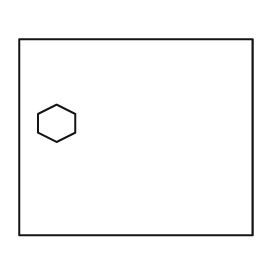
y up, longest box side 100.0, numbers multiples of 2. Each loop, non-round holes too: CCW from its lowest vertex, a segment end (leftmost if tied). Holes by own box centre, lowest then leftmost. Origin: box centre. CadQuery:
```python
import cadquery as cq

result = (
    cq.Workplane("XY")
    .moveTo(-50.0, -42.0)
    .lineTo(50.0, -42.0)
    .lineTo(50.0, 42.0)
    .lineTo(-50.0, 42.0)
    .close()
    .moveTo(-34.0, -2.0)
    .lineTo(-26.0, 2.0)
    .lineTo(-26.0, 10.0)
    .lineTo(-34.0, 14.0)
    .lineTo(-42.0, 10.0)
    .lineTo(-42.0, 2.0)
    .close()
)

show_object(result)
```